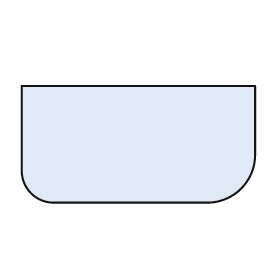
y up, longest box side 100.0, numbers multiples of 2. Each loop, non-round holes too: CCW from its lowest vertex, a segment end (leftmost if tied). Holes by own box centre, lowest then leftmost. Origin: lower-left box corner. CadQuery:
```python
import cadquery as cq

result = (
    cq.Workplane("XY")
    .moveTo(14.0, 0.0)
    .lineTo(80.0, 0.0)
    .threePointArc((94.0, 6.0), (100.0, 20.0))
    .lineTo(100.0, 50.0)
    .lineTo(0.0, 50.0)
    .lineTo(0.0, 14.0)
    .threePointArc((4.0, 4.0), (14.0, 0.0))
    .close()
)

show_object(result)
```